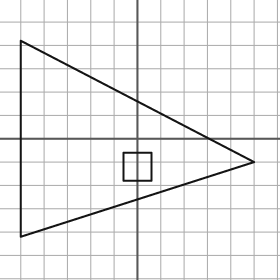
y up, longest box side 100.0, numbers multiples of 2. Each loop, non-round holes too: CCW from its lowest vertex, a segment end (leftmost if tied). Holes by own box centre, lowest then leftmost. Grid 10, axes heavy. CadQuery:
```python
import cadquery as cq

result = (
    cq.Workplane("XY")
    .moveTo(-50.0, -42.0)
    .lineTo(50.0, -10.0)
    .lineTo(-50.0, 42.0)
    .close()
    .moveTo(-6.0, -18.0)
    .lineTo(6.0, -18.0)
    .lineTo(6.0, -6.0)
    .lineTo(-6.0, -6.0)
    .close()
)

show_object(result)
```